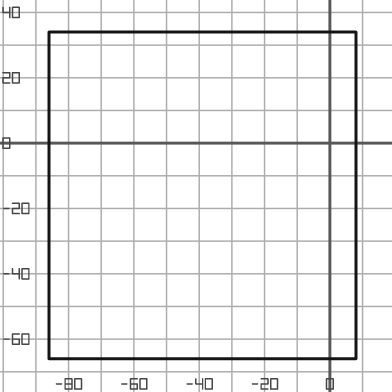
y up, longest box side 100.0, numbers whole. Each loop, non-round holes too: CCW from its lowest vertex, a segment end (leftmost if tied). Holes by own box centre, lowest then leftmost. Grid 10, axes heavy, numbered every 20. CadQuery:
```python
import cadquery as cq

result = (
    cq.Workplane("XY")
    .moveTo(-86.0, -66.0)
    .lineTo(8.0, -66.0)
    .lineTo(8.0, 34.0)
    .lineTo(-86.0, 34.0)
    .close()
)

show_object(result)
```